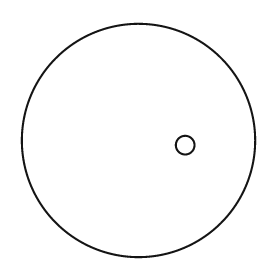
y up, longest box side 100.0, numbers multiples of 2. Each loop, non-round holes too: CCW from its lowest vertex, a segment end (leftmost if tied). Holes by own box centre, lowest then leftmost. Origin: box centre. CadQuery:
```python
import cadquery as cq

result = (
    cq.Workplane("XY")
    .moveTo(0.0, 0.0)
    .circle(50.0)
    .moveTo(20.0, -2.0)
    .circle(4.0)
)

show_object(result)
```